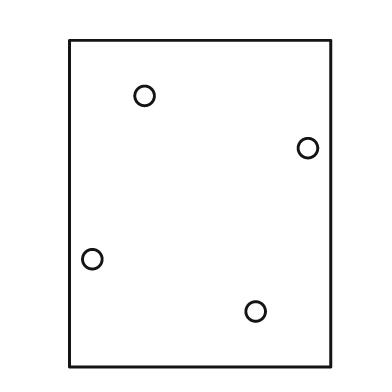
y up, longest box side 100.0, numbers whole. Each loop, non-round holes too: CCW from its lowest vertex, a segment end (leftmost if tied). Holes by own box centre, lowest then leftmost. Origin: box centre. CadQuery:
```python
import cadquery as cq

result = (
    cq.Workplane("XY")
    .moveTo(-40.0, -50.0)
    .lineTo(40.0, -50.0)
    .lineTo(40.0, 50.0)
    .lineTo(-40.0, 50.0)
    .close()
    .moveTo(17.0, -33.0)
    .circle(3.0)
    .moveTo(-33.0, -17.0)
    .circle(3.0)
    .moveTo(33.0, 17.0)
    .circle(3.0)
    .moveTo(-17.0, 33.0)
    .circle(3.0)
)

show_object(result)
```